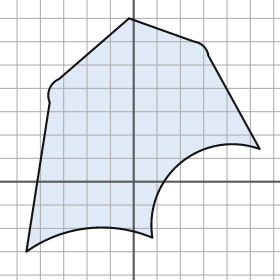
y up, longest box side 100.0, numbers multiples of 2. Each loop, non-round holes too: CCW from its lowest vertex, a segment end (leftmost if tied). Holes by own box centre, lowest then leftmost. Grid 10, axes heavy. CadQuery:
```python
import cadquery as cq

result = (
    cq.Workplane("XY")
    .moveTo(-46.0, -30.0)
    .threePointArc((-20.0, -20.0), (8.0, -24.0))
    .threePointArc((20.0, 8.0), (54.0, 14.0))
    .lineTo(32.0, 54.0)
    .threePointArc((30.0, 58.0), (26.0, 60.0))
    .lineTo(-2.0, 70.0)
    .lineTo(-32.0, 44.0)
    .threePointArc((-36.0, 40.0), (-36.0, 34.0))
    .close()
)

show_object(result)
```